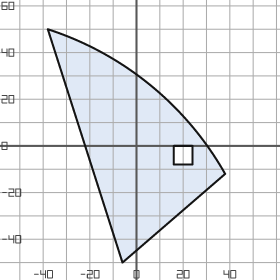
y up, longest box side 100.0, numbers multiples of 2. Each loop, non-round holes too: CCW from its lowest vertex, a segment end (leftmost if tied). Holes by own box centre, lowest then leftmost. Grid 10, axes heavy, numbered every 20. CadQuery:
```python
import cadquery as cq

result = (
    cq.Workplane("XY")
    .moveTo(-6.0, -50.0)
    .lineTo(38.0, -12.0)
    .threePointArc((6.0, 26.0), (-38.0, 50.0))
    .close()
    .moveTo(16.0, -8.0)
    .lineTo(24.0, -8.0)
    .lineTo(24.0, 0.0)
    .lineTo(16.0, 0.0)
    .close()
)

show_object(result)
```